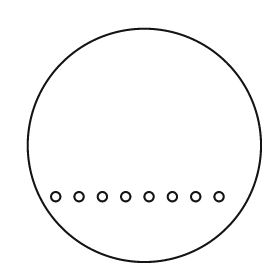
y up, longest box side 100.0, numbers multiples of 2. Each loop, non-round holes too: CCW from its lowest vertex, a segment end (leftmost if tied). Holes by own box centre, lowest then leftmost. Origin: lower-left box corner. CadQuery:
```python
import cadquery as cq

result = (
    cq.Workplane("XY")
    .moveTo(50.0, 50.0)
    .circle(50.0)
    .moveTo(12.0, 28.0)
    .circle(2.0)
    .moveTo(22.0, 28.0)
    .circle(2.0)
    .moveTo(32.0, 28.0)
    .circle(2.0)
    .moveTo(42.0, 28.0)
    .circle(2.0)
    .moveTo(52.0, 28.0)
    .circle(2.0)
    .moveTo(62.0, 28.0)
    .circle(2.0)
    .moveTo(72.0, 28.0)
    .circle(2.0)
    .moveTo(82.0, 28.0)
    .circle(2.0)
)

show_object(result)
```